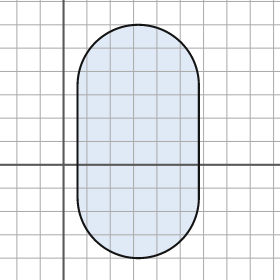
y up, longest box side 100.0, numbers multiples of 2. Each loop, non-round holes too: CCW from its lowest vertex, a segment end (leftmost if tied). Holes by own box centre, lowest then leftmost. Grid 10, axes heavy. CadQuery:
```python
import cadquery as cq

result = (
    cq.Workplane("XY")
    .moveTo(6.0, -14.0)
    .threePointArc((32.0, -40.0), (58.0, -14.0))
    .lineTo(58.0, 34.0)
    .threePointArc((32.0, 60.0), (6.0, 34.0))
    .close()
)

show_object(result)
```